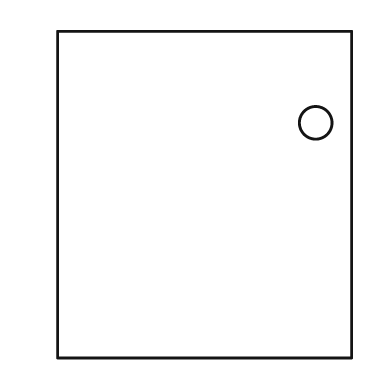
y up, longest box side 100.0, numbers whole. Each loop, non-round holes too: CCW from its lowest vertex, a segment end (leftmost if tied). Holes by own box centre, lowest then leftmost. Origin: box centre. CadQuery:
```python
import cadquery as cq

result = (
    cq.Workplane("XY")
    .moveTo(-45.0, -50.0)
    .lineTo(45.0, -50.0)
    .lineTo(45.0, 50.0)
    .lineTo(-45.0, 50.0)
    .close()
    .moveTo(34.0, 22.0)
    .circle(5.0)
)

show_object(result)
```